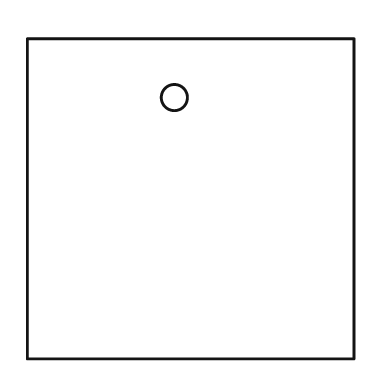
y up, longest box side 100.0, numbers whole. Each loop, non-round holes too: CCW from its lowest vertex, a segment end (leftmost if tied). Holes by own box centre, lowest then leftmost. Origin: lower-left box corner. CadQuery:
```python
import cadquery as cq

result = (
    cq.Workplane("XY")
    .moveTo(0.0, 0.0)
    .lineTo(100.0, 0.0)
    .lineTo(100.0, 98.0)
    .lineTo(0.0, 98.0)
    .close()
    .moveTo(45.0, 80.0)
    .circle(4.0)
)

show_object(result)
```